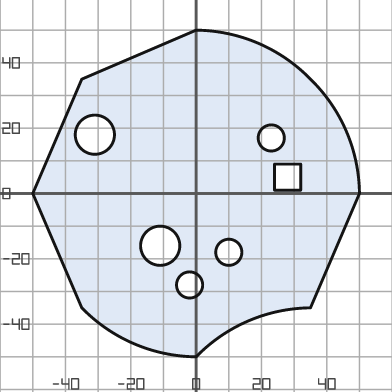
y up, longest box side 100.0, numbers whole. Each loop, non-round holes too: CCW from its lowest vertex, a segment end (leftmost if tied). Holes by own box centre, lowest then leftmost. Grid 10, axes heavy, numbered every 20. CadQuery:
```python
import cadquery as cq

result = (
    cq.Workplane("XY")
    .moveTo(0.0, -50.0)
    .threePointArc((16.0, -39.0), (35.0, -35.0))
    .lineTo(50.0, 0.0)
    .threePointArc((46.0, 19.0), (35.0, 35.0))
    .threePointArc((19.0, 46.0), (0.0, 50.0))
    .lineTo(-35.0, 35.0)
    .lineTo(-50.0, 0.0)
    .lineTo(-35.0, -35.0)
    .threePointArc((-19.0, -46.0), (0.0, -50.0))
    .close()
    .moveTo(-2.0, -28.0)
    .circle(4.0)
    .moveTo(10.0, -18.0)
    .circle(4.0)
    .moveTo(-11.0, -16.0)
    .circle(6.0)
    .moveTo(24.0, 1.0)
    .lineTo(32.0, 1.0)
    .lineTo(32.0, 9.0)
    .lineTo(24.0, 9.0)
    .close()
    .moveTo(23.0, 17.0)
    .circle(4.0)
    .moveTo(-31.0, 18.0)
    .circle(6.0)
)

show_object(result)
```